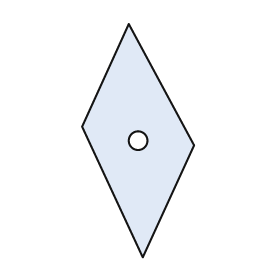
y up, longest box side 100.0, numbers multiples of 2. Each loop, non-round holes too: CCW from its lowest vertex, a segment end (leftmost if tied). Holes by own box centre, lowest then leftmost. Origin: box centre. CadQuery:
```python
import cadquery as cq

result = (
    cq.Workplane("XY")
    .moveTo(2.0, -50.0)
    .lineTo(24.0, -2.0)
    .lineTo(-4.0, 50.0)
    .lineTo(-24.0, 6.0)
    .close()
    .moveTo(0.0, 0.0)
    .circle(4.0)
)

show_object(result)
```